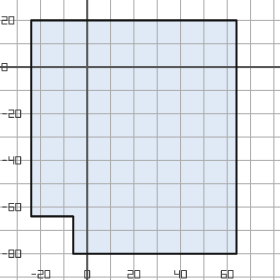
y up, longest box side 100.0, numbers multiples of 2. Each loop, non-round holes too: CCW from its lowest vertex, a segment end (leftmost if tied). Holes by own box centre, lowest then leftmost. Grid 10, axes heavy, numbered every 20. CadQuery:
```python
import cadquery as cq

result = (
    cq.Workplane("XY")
    .moveTo(-6.0, -80.0)
    .lineTo(64.0, -80.0)
    .lineTo(64.0, 20.0)
    .lineTo(-24.0, 20.0)
    .lineTo(-24.0, -64.0)
    .lineTo(-6.0, -64.0)
    .close()
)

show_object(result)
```